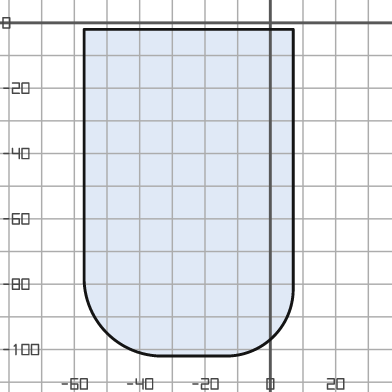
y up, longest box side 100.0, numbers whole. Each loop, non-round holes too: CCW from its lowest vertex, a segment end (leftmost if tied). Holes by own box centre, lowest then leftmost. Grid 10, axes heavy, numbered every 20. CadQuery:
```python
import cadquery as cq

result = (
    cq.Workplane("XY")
    .moveTo(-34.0, -102.0)
    .lineTo(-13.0, -102.0)
    .threePointArc((1.0, -96.0), (7.0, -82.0))
    .lineTo(7.0, -2.0)
    .lineTo(-57.0, -2.0)
    .lineTo(-57.0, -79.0)
    .threePointArc((-50.0, -95.0), (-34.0, -102.0))
    .close()
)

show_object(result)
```